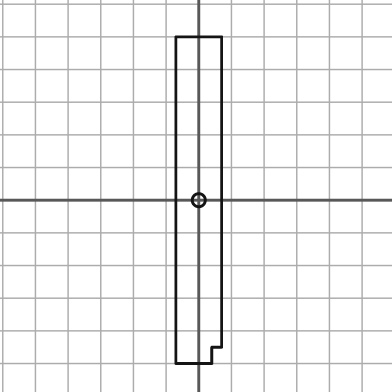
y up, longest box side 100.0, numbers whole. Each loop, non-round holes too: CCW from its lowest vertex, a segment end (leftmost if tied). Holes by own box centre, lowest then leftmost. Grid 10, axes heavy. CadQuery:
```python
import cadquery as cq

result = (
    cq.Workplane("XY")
    .moveTo(-7.0, -50.0)
    .lineTo(4.0, -50.0)
    .lineTo(4.0, -45.0)
    .lineTo(7.0, -45.0)
    .lineTo(7.0, 50.0)
    .lineTo(-7.0, 50.0)
    .close()
    .moveTo(0.0, 0.0)
    .circle(2.0)
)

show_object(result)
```